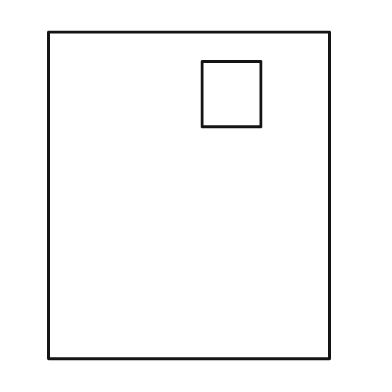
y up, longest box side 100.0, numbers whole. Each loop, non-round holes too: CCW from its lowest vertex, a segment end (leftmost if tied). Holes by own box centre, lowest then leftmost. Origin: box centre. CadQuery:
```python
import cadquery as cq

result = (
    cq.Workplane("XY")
    .moveTo(-43.0, -50.0)
    .lineTo(43.0, -50.0)
    .lineTo(43.0, 50.0)
    .lineTo(-43.0, 50.0)
    .close()
    .moveTo(4.0, 21.0)
    .lineTo(22.0, 21.0)
    .lineTo(22.0, 41.0)
    .lineTo(4.0, 41.0)
    .close()
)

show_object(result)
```